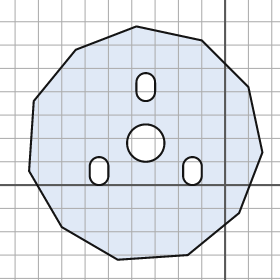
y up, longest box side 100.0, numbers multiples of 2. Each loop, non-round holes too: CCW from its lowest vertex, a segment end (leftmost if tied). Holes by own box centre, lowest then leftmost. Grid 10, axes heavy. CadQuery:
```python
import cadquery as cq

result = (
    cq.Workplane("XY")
    .moveTo(-46.0, -32.0)
    .lineTo(-16.0, -30.0)
    .lineTo(6.0, -12.0)
    .lineTo(16.0, 14.0)
    .lineTo(10.0, 42.0)
    .lineTo(-10.0, 62.0)
    .lineTo(-38.0, 68.0)
    .lineTo(-64.0, 58.0)
    .lineTo(-82.0, 36.0)
    .lineTo(-84.0, 6.0)
    .lineTo(-70.0, -18.0)
    .close()
    .moveTo(-58.0, 4.0)
    .threePointArc((-54.0, 0.0), (-50.0, 4.0))
    .lineTo(-50.0, 8.0)
    .threePointArc((-54.0, 12.0), (-58.0, 8.0))
    .close()
    .moveTo(-18.0, 4.0)
    .threePointArc((-14.0, 0.0), (-10.0, 4.0))
    .lineTo(-10.0, 8.0)
    .threePointArc((-14.0, 12.0), (-18.0, 8.0))
    .close()
    .moveTo(-34.0, 18.0)
    .circle(8.0)
    .moveTo(-38.0, 40.0)
    .threePointArc((-34.0, 36.0), (-30.0, 40.0))
    .lineTo(-30.0, 44.0)
    .threePointArc((-34.0, 48.0), (-38.0, 44.0))
    .close()
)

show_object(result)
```